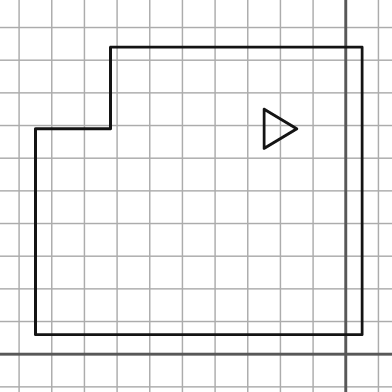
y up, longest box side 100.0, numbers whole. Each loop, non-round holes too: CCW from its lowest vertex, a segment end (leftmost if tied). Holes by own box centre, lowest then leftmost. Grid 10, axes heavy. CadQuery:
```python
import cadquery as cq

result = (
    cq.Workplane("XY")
    .moveTo(-95.0, 6.0)
    .lineTo(5.0, 6.0)
    .lineTo(5.0, 94.0)
    .lineTo(-72.0, 94.0)
    .lineTo(-72.0, 69.0)
    .lineTo(-95.0, 69.0)
    .close()
    .moveTo(-25.0, 63.0)
    .lineTo(-15.0, 69.0)
    .lineTo(-25.0, 75.0)
    .close()
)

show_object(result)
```